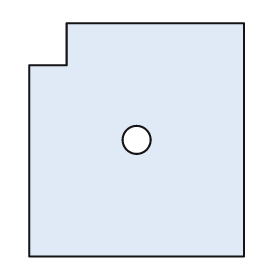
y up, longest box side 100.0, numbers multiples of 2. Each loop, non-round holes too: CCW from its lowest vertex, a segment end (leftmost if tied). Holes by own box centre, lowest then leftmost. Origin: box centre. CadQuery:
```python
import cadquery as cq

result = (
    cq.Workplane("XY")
    .moveTo(-46.0, -50.0)
    .lineTo(46.0, -50.0)
    .lineTo(46.0, 50.0)
    .lineTo(-30.0, 50.0)
    .lineTo(-30.0, 32.0)
    .lineTo(-46.0, 32.0)
    .close()
    .moveTo(0.0, 0.0)
    .circle(6.0)
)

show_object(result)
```